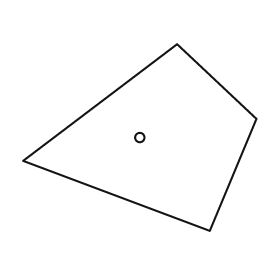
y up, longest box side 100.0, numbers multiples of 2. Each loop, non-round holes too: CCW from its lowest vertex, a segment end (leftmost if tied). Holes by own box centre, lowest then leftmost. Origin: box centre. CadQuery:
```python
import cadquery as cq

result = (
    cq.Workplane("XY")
    .moveTo(30.0, -40.0)
    .lineTo(50.0, 8.0)
    .lineTo(16.0, 40.0)
    .lineTo(-50.0, -10.0)
    .close()
    .moveTo(0.0, 0.0)
    .circle(2.0)
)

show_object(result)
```